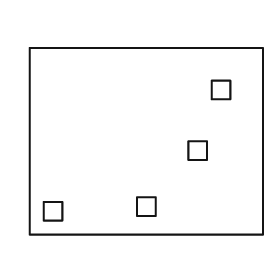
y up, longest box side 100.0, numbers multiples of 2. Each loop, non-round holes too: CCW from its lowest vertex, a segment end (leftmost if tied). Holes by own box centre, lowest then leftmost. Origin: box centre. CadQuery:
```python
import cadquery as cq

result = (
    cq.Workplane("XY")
    .moveTo(-50.0, -40.0)
    .lineTo(50.0, -40.0)
    .lineTo(50.0, 40.0)
    .lineTo(-50.0, 40.0)
    .close()
    .moveTo(-44.0, -34.0)
    .lineTo(-36.0, -34.0)
    .lineTo(-36.0, -26.0)
    .lineTo(-44.0, -26.0)
    .close()
    .moveTo(-4.0, -32.0)
    .lineTo(4.0, -32.0)
    .lineTo(4.0, -24.0)
    .lineTo(-4.0, -24.0)
    .close()
    .moveTo(18.0, -8.0)
    .lineTo(26.0, -8.0)
    .lineTo(26.0, 0.0)
    .lineTo(18.0, 0.0)
    .close()
    .moveTo(28.0, 18.0)
    .lineTo(36.0, 18.0)
    .lineTo(36.0, 26.0)
    .lineTo(28.0, 26.0)
    .close()
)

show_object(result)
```